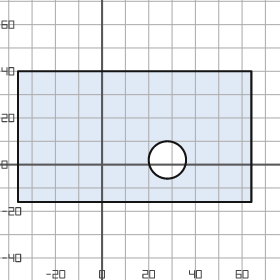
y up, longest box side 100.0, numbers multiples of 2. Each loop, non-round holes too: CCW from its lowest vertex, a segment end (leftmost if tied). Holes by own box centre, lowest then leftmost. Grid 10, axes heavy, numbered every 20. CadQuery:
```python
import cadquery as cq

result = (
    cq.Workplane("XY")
    .moveTo(-36.0, -16.0)
    .lineTo(64.0, -16.0)
    .lineTo(64.0, 40.0)
    .lineTo(-36.0, 40.0)
    .close()
    .moveTo(28.0, 2.0)
    .circle(8.0)
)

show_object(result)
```